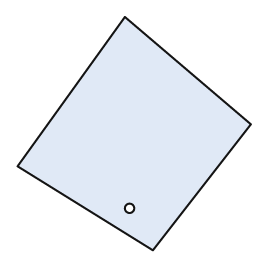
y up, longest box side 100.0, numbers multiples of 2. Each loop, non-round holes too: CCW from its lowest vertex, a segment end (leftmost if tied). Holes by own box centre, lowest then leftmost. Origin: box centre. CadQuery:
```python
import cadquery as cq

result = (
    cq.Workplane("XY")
    .moveTo(8.0, -50.0)
    .lineTo(50.0, 4.0)
    .lineTo(-4.0, 50.0)
    .lineTo(-50.0, -14.0)
    .close()
    .moveTo(-2.0, -32.0)
    .circle(2.0)
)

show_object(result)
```